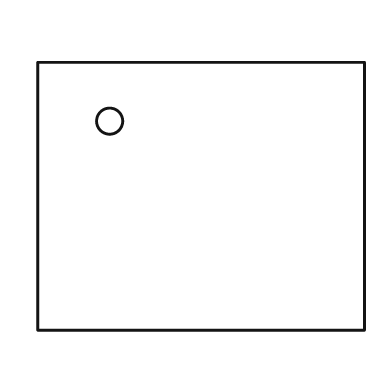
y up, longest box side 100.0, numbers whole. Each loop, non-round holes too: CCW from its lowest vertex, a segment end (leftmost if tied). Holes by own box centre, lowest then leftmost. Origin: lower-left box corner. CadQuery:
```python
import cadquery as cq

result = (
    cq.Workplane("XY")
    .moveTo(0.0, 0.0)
    .lineTo(100.0, 0.0)
    .lineTo(100.0, 82.0)
    .lineTo(0.0, 82.0)
    .close()
    .moveTo(22.0, 64.0)
    .circle(4.0)
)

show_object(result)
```